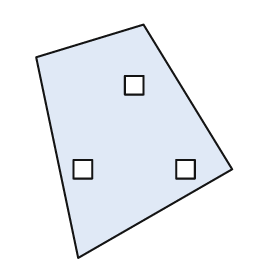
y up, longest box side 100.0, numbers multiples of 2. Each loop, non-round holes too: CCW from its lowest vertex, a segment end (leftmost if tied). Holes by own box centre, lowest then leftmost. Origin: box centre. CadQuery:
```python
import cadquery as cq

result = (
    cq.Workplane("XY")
    .moveTo(-24.0, -50.0)
    .lineTo(42.0, -12.0)
    .lineTo(4.0, 50.0)
    .lineTo(-42.0, 36.0)
    .close()
    .moveTo(-26.0, -16.0)
    .lineTo(-18.0, -16.0)
    .lineTo(-18.0, -8.0)
    .lineTo(-26.0, -8.0)
    .close()
    .moveTo(18.0, -16.0)
    .lineTo(26.0, -16.0)
    .lineTo(26.0, -8.0)
    .lineTo(18.0, -8.0)
    .close()
    .moveTo(-4.0, 20.0)
    .lineTo(4.0, 20.0)
    .lineTo(4.0, 28.0)
    .lineTo(-4.0, 28.0)
    .close()
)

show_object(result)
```